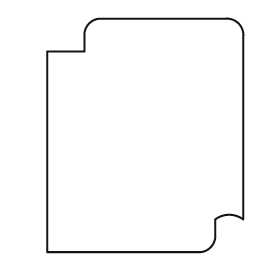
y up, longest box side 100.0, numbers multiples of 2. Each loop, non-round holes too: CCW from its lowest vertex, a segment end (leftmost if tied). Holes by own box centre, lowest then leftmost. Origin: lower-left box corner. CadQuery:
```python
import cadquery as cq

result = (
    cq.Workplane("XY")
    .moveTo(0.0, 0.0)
    .lineTo(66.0, 0.0)
    .threePointArc((70.0, 2.0), (72.0, 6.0))
    .lineTo(72.0, 14.0)
    .threePointArc((78.0, 16.0), (84.0, 14.0))
    .lineTo(84.0, 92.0)
    .threePointArc((82.0, 98.0), (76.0, 100.0))
    .lineTo(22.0, 100.0)
    .threePointArc((18.0, 98.0), (16.0, 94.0))
    .lineTo(16.0, 86.0)
    .lineTo(0.0, 86.0)
    .close()
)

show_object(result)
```